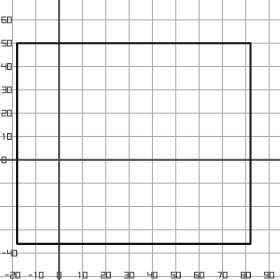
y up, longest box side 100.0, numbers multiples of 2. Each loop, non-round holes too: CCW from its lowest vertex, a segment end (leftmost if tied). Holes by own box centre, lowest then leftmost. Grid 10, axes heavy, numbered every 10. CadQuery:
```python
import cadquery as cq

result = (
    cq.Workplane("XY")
    .moveTo(-18.0, -36.0)
    .lineTo(82.0, -36.0)
    .lineTo(82.0, 50.0)
    .lineTo(-18.0, 50.0)
    .close()
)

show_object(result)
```